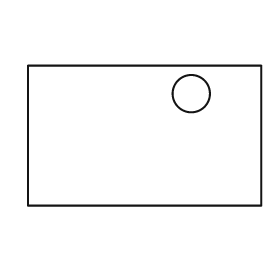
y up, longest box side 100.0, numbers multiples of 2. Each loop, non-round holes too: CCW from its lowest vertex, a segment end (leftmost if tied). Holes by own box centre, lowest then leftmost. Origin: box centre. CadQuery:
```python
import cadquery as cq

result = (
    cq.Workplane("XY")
    .moveTo(-50.0, -30.0)
    .lineTo(50.0, -30.0)
    .lineTo(50.0, 30.0)
    .lineTo(-50.0, 30.0)
    .close()
    .moveTo(20.0, 18.0)
    .circle(8.0)
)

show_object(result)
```